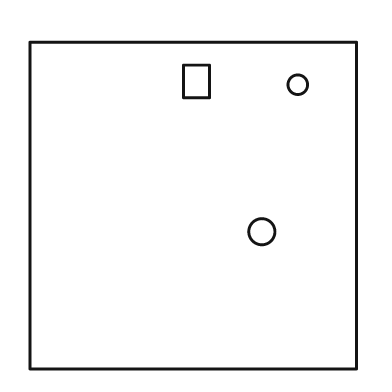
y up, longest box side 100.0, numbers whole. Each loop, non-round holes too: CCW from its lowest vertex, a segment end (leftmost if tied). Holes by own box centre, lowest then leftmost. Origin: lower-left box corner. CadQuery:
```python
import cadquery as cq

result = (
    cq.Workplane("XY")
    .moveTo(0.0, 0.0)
    .lineTo(100.0, 0.0)
    .lineTo(100.0, 100.0)
    .lineTo(0.0, 100.0)
    .close()
    .moveTo(71.0, 42.0)
    .circle(4.0)
    .moveTo(82.0, 87.0)
    .circle(3.0)
    .moveTo(47.0, 83.0)
    .lineTo(55.0, 83.0)
    .lineTo(55.0, 93.0)
    .lineTo(47.0, 93.0)
    .close()
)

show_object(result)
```